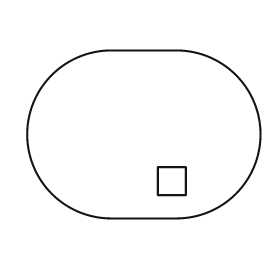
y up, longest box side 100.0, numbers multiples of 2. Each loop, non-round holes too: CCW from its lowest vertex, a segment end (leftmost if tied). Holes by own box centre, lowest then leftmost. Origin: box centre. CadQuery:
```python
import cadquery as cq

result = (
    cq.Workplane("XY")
    .moveTo(-14.0, -36.0)
    .lineTo(14.0, -36.0)
    .threePointArc((50.0, 0.0), (14.0, 36.0))
    .lineTo(-14.0, 36.0)
    .threePointArc((-50.0, 0.0), (-14.0, -36.0))
    .close()
    .moveTo(6.0, -26.0)
    .lineTo(18.0, -26.0)
    .lineTo(18.0, -14.0)
    .lineTo(6.0, -14.0)
    .close()
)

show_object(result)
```